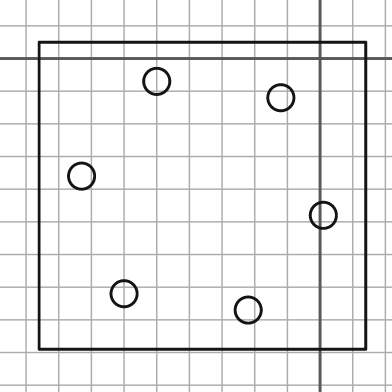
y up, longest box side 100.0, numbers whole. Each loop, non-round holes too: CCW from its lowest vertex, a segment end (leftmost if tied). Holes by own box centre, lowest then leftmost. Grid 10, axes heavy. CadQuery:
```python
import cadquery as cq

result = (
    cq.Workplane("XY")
    .moveTo(-86.0, -89.0)
    .lineTo(14.0, -89.0)
    .lineTo(14.0, 5.0)
    .lineTo(-86.0, 5.0)
    .close()
    .moveTo(-22.0, -77.0)
    .circle(4.0)
    .moveTo(-60.0, -72.0)
    .circle(4.0)
    .moveTo(1.0, -48.0)
    .circle(4.0)
    .moveTo(-73.0, -36.0)
    .circle(4.0)
    .moveTo(-12.0, -12.0)
    .circle(4.0)
    .moveTo(-50.0, -7.0)
    .circle(4.0)
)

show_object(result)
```